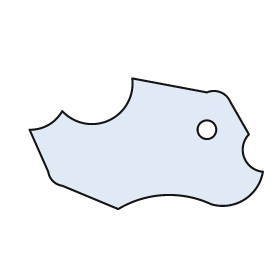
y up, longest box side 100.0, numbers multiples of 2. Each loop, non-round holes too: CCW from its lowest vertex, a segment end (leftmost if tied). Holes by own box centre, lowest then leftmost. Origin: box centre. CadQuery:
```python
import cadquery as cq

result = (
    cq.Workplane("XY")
    .moveTo(-12.0, -28.0)
    .threePointArc((8.0, -22.0), (28.0, -26.0))
    .threePointArc((42.0, -24.0), (50.0, -12.0))
    .threePointArc((42.0, -6.0), (44.0, 4.0))
    .lineTo(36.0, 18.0)
    .threePointArc((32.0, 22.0), (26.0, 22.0))
    .lineTo(-6.0, 28.0)
    .threePointArc((-16.0, 10.0), (-36.0, 14.0))
    .threePointArc((-42.0, 8.0), (-50.0, 6.0))
    .lineTo(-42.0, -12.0)
    .threePointArc((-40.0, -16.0), (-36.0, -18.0))
    .close()
    .moveTo(26.0, 6.0)
    .circle(4.0)
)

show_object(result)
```